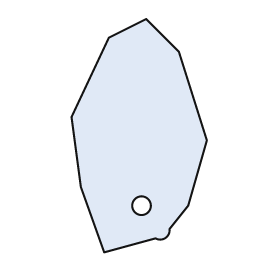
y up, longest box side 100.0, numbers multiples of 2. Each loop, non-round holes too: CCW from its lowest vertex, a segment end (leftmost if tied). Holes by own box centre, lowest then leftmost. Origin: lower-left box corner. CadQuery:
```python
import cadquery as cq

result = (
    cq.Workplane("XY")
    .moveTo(14.0, 0.0)
    .lineTo(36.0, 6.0)
    .threePointArc((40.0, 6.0), (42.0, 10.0))
    .lineTo(50.0, 20.0)
    .lineTo(58.0, 48.0)
    .lineTo(46.0, 86.0)
    .lineTo(32.0, 100.0)
    .lineTo(16.0, 92.0)
    .lineTo(0.0, 58.0)
    .lineTo(4.0, 28.0)
    .close()
    .moveTo(30.0, 20.0)
    .circle(4.0)
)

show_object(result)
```